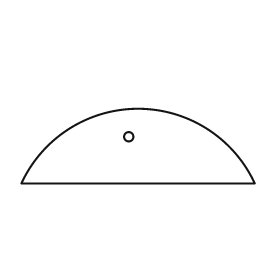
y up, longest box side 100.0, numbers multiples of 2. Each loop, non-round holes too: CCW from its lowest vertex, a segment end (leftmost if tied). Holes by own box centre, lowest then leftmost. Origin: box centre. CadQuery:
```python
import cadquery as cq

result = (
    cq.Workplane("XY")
    .moveTo(-50.0, -16.0)
    .lineTo(50.0, -16.0)
    .threePointArc((0.0, 16.0), (-50.0, -16.0))
    .close()
    .moveTo(-4.0, 4.0)
    .circle(2.0)
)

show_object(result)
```